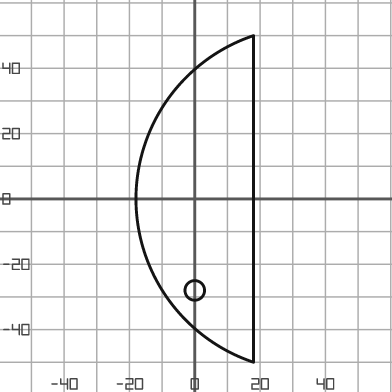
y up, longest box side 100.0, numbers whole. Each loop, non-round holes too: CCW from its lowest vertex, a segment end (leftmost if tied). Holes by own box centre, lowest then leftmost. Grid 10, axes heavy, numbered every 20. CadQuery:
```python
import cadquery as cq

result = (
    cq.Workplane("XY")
    .moveTo(18.0, -50.0)
    .lineTo(18.0, 50.0)
    .threePointArc((-18.0, 0.0), (18.0, -50.0))
    .close()
    .moveTo(0.0, -28.0)
    .circle(3.0)
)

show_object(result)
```